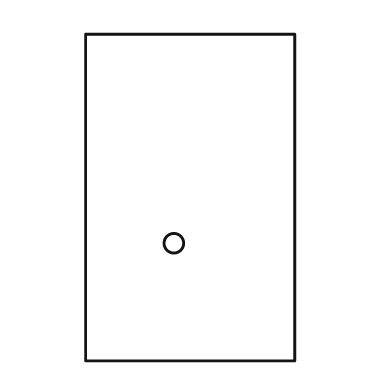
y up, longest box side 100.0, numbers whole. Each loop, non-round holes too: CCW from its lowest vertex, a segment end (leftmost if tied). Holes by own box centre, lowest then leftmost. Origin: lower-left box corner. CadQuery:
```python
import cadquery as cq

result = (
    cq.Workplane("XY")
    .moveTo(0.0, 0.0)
    .lineTo(64.0, 0.0)
    .lineTo(64.0, 100.0)
    .lineTo(0.0, 100.0)
    .close()
    .moveTo(27.0, 36.0)
    .circle(3.0)
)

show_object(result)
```